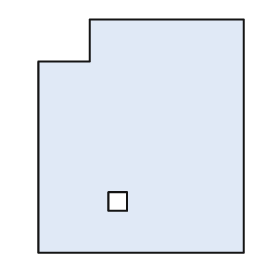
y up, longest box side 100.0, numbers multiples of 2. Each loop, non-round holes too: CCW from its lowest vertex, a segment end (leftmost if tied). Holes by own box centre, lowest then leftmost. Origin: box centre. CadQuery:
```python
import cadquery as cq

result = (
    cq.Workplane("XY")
    .moveTo(-44.0, -50.0)
    .lineTo(44.0, -50.0)
    .lineTo(44.0, 50.0)
    .lineTo(-22.0, 50.0)
    .lineTo(-22.0, 32.0)
    .lineTo(-44.0, 32.0)
    .close()
    .moveTo(-14.0, -32.0)
    .lineTo(-6.0, -32.0)
    .lineTo(-6.0, -24.0)
    .lineTo(-14.0, -24.0)
    .close()
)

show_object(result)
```